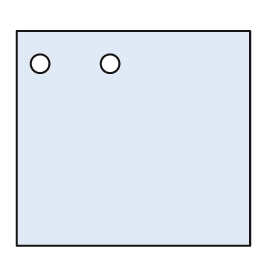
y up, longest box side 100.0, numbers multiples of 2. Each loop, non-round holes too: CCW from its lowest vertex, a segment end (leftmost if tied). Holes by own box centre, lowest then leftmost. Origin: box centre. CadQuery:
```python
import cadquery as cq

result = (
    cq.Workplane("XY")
    .moveTo(-50.0, -46.0)
    .lineTo(50.0, -46.0)
    .lineTo(50.0, 46.0)
    .lineTo(-50.0, 46.0)
    .close()
    .moveTo(-40.0, 32.0)
    .circle(4.0)
    .moveTo(-10.0, 32.0)
    .circle(4.0)
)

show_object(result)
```